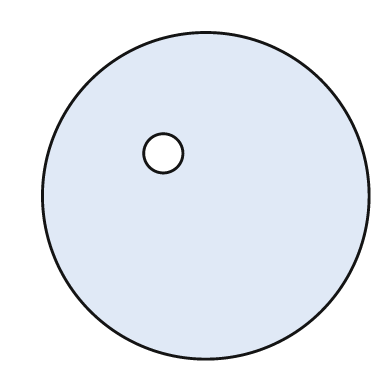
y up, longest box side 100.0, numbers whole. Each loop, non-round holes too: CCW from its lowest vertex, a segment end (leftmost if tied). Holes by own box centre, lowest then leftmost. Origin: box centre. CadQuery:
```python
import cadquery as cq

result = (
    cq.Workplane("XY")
    .moveTo(0.0, 0.0)
    .circle(50.0)
    .moveTo(-13.0, 13.0)
    .circle(6.0)
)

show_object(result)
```